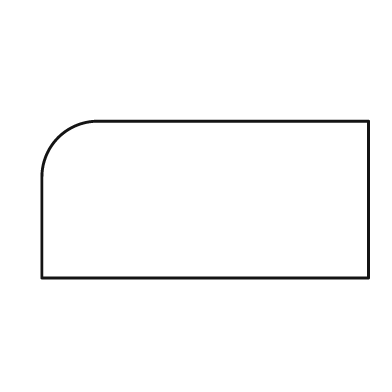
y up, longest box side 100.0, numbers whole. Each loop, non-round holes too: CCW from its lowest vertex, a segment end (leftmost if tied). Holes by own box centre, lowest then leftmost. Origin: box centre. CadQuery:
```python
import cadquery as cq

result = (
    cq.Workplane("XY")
    .moveTo(-50.0, -24.0)
    .lineTo(50.0, -24.0)
    .lineTo(50.0, 24.0)
    .lineTo(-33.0, 24.0)
    .threePointArc((-45.0, 19.0), (-50.0, 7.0))
    .close()
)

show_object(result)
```